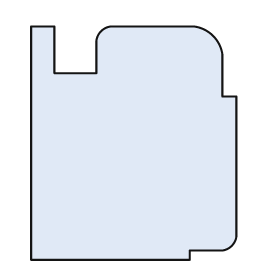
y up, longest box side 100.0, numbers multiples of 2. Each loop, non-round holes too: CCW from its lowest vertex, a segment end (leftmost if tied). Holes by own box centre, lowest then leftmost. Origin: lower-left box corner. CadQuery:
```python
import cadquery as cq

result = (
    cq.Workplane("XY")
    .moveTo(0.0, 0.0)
    .lineTo(68.0, 0.0)
    .lineTo(68.0, 4.0)
    .lineTo(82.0, 4.0)
    .threePointArc((86.0, 6.0), (88.0, 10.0))
    .lineTo(88.0, 70.0)
    .lineTo(82.0, 70.0)
    .lineTo(82.0, 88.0)
    .threePointArc((78.0, 96.0), (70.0, 100.0))
    .lineTo(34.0, 100.0)
    .threePointArc((30.0, 98.0), (28.0, 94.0))
    .lineTo(28.0, 80.0)
    .lineTo(10.0, 80.0)
    .lineTo(10.0, 100.0)
    .lineTo(0.0, 100.0)
    .close()
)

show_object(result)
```